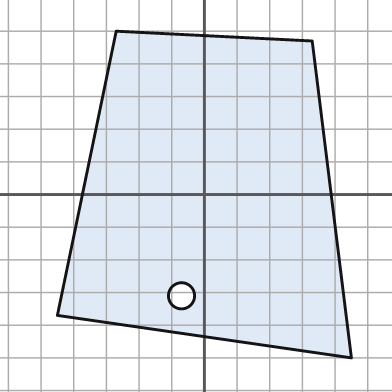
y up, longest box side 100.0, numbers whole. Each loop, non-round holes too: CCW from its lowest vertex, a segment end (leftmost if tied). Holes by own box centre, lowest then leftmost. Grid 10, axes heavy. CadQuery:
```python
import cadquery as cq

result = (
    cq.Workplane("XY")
    .moveTo(45.0, -50.0)
    .lineTo(33.0, 47.0)
    .lineTo(-27.0, 50.0)
    .lineTo(-45.0, -37.0)
    .close()
    .moveTo(-7.0, -31.0)
    .circle(4.0)
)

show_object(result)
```